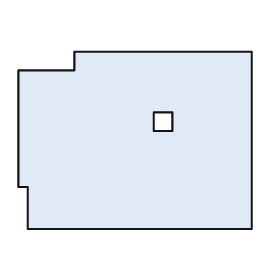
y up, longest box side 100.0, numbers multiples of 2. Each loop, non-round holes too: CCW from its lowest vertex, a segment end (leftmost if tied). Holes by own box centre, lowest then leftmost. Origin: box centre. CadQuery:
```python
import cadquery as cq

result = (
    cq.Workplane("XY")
    .moveTo(-46.0, -38.0)
    .lineTo(50.0, -38.0)
    .lineTo(50.0, 38.0)
    .lineTo(-26.0, 38.0)
    .lineTo(-26.0, 30.0)
    .lineTo(-50.0, 30.0)
    .lineTo(-50.0, -20.0)
    .lineTo(-46.0, -20.0)
    .close()
    .moveTo(8.0, 4.0)
    .lineTo(16.0, 4.0)
    .lineTo(16.0, 12.0)
    .lineTo(8.0, 12.0)
    .close()
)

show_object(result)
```